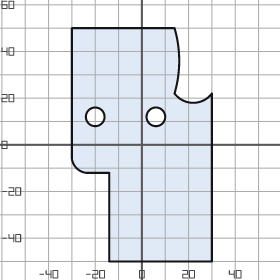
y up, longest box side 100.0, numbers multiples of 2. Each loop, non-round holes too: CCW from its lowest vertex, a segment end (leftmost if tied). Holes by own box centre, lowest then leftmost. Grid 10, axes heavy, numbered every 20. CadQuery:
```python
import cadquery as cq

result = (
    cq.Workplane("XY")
    .moveTo(-14.0, -50.0)
    .lineTo(30.0, -50.0)
    .lineTo(30.0, 22.0)
    .threePointArc((22.0, 18.0), (14.0, 22.0))
    .threePointArc((16.0, 36.0), (14.0, 50.0))
    .lineTo(-30.0, 50.0)
    .lineTo(-30.0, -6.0)
    .threePointArc((-28.0, -10.0), (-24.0, -12.0))
    .lineTo(-14.0, -12.0)
    .close()
    .moveTo(-20.0, 12.0)
    .circle(4.0)
    .moveTo(6.0, 12.0)
    .circle(4.0)
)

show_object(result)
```